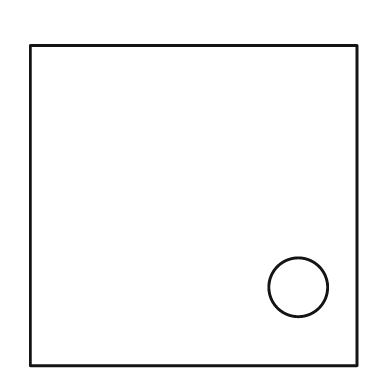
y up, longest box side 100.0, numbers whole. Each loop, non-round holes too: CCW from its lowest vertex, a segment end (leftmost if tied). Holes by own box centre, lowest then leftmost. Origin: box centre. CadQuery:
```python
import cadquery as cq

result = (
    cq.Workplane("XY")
    .moveTo(-50.0, -49.0)
    .lineTo(50.0, -49.0)
    .lineTo(50.0, 49.0)
    .lineTo(-50.0, 49.0)
    .close()
    .moveTo(32.0, -25.0)
    .circle(9.0)
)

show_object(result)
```